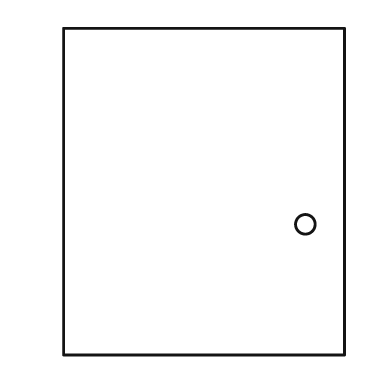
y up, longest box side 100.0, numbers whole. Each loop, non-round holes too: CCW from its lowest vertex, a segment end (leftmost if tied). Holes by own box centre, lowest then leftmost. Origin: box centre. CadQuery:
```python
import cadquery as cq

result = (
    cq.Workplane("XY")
    .moveTo(-43.0, -50.0)
    .lineTo(43.0, -50.0)
    .lineTo(43.0, 50.0)
    .lineTo(-43.0, 50.0)
    .close()
    .moveTo(31.0, -10.0)
    .circle(3.0)
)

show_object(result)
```